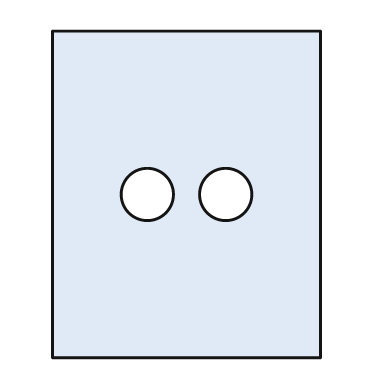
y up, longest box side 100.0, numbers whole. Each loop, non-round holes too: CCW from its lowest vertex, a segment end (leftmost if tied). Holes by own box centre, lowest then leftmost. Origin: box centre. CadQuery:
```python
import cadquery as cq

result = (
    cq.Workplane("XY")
    .moveTo(-41.0, -50.0)
    .lineTo(41.0, -50.0)
    .lineTo(41.0, 50.0)
    .lineTo(-41.0, 50.0)
    .close()
    .moveTo(-12.0, 0.0)
    .circle(8.0)
    .moveTo(12.0, 0.0)
    .circle(8.0)
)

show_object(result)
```